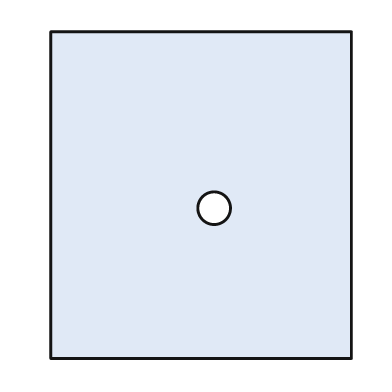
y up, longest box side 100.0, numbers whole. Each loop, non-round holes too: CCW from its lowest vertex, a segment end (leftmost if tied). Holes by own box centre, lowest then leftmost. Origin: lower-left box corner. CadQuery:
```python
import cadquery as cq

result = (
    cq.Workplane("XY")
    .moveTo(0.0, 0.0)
    .lineTo(92.0, 0.0)
    .lineTo(92.0, 100.0)
    .lineTo(0.0, 100.0)
    .close()
    .moveTo(50.0, 46.0)
    .circle(5.0)
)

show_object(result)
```